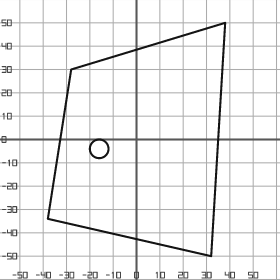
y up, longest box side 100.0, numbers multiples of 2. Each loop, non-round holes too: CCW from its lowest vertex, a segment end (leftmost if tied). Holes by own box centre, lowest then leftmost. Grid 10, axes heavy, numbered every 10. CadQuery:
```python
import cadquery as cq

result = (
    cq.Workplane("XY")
    .moveTo(32.0, -50.0)
    .lineTo(38.0, 50.0)
    .lineTo(-28.0, 30.0)
    .lineTo(-38.0, -34.0)
    .close()
    .moveTo(-16.0, -4.0)
    .circle(4.0)
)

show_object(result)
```